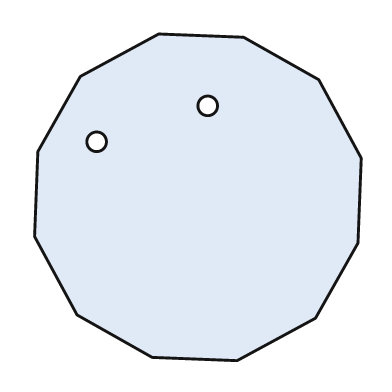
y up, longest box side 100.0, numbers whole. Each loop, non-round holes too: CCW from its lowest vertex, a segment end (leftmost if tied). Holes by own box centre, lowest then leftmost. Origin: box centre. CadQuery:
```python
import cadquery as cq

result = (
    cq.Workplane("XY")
    .moveTo(12.0, -50.0)
    .lineTo(36.0, -37.0)
    .lineTo(49.0, -14.0)
    .lineTo(50.0, 12.0)
    .lineTo(37.0, 36.0)
    .lineTo(14.0, 49.0)
    .lineTo(-12.0, 50.0)
    .lineTo(-36.0, 37.0)
    .lineTo(-49.0, 14.0)
    .lineTo(-50.0, -12.0)
    .lineTo(-37.0, -36.0)
    .lineTo(-14.0, -49.0)
    .close()
    .moveTo(-31.0, 17.0)
    .circle(3.0)
    .moveTo(3.0, 28.0)
    .circle(3.0)
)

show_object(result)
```